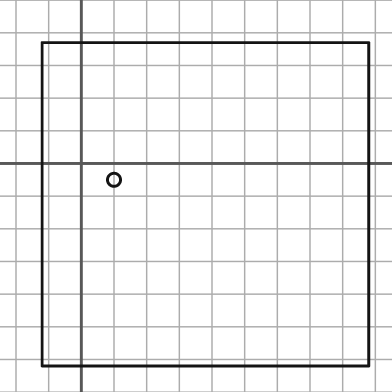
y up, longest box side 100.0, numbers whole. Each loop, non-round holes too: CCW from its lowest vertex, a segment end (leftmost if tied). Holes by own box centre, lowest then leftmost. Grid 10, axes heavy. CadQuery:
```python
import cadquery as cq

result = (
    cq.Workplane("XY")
    .moveTo(-12.0, -62.0)
    .lineTo(88.0, -62.0)
    .lineTo(88.0, 37.0)
    .lineTo(-12.0, 37.0)
    .close()
    .moveTo(10.0, -5.0)
    .circle(2.0)
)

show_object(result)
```